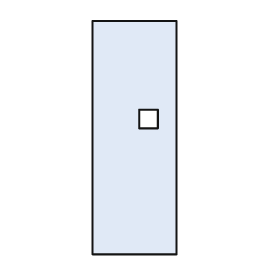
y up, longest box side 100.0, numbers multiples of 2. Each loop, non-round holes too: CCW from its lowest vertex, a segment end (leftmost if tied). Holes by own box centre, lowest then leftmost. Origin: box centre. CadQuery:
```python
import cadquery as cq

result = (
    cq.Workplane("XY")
    .moveTo(-18.0, -50.0)
    .lineTo(18.0, -50.0)
    .lineTo(18.0, 50.0)
    .lineTo(-18.0, 50.0)
    .close()
    .moveTo(2.0, 4.0)
    .lineTo(10.0, 4.0)
    .lineTo(10.0, 12.0)
    .lineTo(2.0, 12.0)
    .close()
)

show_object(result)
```